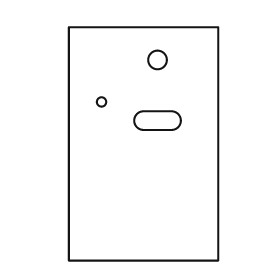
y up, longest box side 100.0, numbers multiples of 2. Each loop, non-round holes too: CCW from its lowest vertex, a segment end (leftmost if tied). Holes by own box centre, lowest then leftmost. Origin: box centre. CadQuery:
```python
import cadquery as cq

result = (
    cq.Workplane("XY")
    .moveTo(-32.0, -50.0)
    .lineTo(32.0, -50.0)
    .lineTo(32.0, 50.0)
    .lineTo(-32.0, 50.0)
    .close()
    .moveTo(0.0, 6.0)
    .lineTo(12.0, 6.0)
    .threePointArc((16.0, 10.0), (12.0, 14.0))
    .lineTo(0.0, 14.0)
    .threePointArc((-4.0, 10.0), (0.0, 6.0))
    .close()
    .moveTo(-18.0, 18.0)
    .circle(2.0)
    .moveTo(6.0, 36.0)
    .circle(4.0)
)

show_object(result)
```